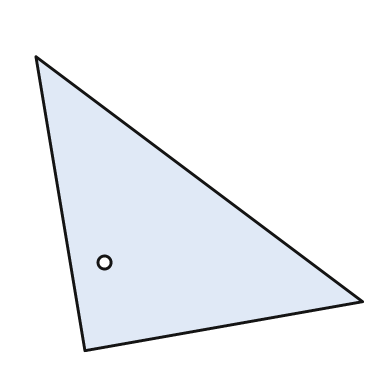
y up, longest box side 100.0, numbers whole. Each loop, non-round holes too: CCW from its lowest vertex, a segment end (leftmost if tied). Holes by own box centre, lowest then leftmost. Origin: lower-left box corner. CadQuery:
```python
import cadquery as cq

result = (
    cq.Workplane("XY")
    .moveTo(15.0, 0.0)
    .lineTo(100.0, 15.0)
    .lineTo(0.0, 90.0)
    .close()
    .moveTo(21.0, 27.0)
    .circle(2.0)
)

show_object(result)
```